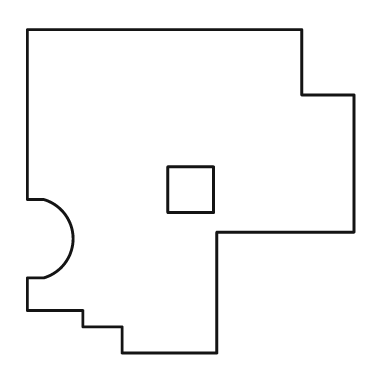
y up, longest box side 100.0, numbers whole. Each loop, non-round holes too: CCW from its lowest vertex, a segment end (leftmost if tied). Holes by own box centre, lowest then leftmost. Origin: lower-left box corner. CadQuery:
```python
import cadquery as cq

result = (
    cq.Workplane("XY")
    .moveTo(29.0, 0.0)
    .lineTo(58.0, 0.0)
    .lineTo(58.0, 37.0)
    .lineTo(100.0, 37.0)
    .lineTo(100.0, 79.0)
    .lineTo(84.0, 79.0)
    .lineTo(84.0, 99.0)
    .lineTo(0.0, 99.0)
    .lineTo(0.0, 47.0)
    .lineTo(5.0, 47.0)
    .threePointArc((14.0, 35.0), (5.0, 23.0))
    .lineTo(0.0, 23.0)
    .lineTo(0.0, 13.0)
    .lineTo(17.0, 13.0)
    .lineTo(17.0, 8.0)
    .lineTo(29.0, 8.0)
    .close()
    .moveTo(43.0, 43.0)
    .lineTo(57.0, 43.0)
    .lineTo(57.0, 57.0)
    .lineTo(43.0, 57.0)
    .close()
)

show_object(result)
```